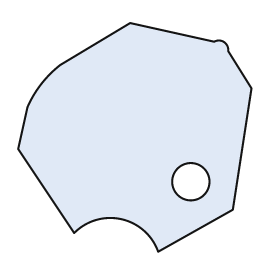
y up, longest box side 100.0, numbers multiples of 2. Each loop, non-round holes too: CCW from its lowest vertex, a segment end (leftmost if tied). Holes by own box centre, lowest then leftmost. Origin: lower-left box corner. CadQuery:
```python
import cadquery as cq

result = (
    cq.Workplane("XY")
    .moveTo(60.0, 0.0)
    .lineTo(92.0, 18.0)
    .lineTo(100.0, 70.0)
    .lineTo(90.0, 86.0)
    .threePointArc((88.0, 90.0), (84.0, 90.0))
    .lineTo(48.0, 98.0)
    .lineTo(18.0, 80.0)
    .threePointArc((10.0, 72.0), (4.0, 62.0))
    .lineTo(0.0, 44.0)
    .lineTo(24.0, 8.0)
    .threePointArc((44.0, 14.0), (60.0, 0.0))
    .close()
    .moveTo(74.0, 30.0)
    .circle(8.0)
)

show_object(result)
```